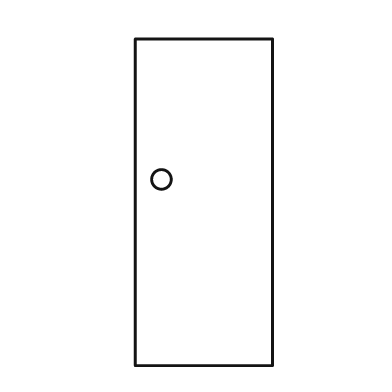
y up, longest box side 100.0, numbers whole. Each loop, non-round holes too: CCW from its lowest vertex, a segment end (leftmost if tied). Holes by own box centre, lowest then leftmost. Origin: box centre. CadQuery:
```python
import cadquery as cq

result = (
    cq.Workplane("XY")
    .moveTo(-21.0, -50.0)
    .lineTo(21.0, -50.0)
    .lineTo(21.0, 50.0)
    .lineTo(-21.0, 50.0)
    .close()
    .moveTo(-13.0, 7.0)
    .circle(3.0)
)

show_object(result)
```